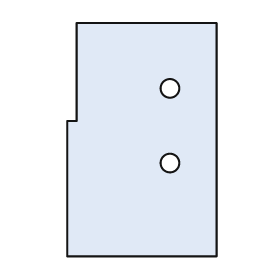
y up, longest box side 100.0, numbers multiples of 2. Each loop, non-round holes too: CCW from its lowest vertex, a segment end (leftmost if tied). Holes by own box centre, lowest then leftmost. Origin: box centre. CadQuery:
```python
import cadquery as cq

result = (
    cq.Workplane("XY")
    .moveTo(-32.0, -50.0)
    .lineTo(32.0, -50.0)
    .lineTo(32.0, 50.0)
    .lineTo(-28.0, 50.0)
    .lineTo(-28.0, 8.0)
    .lineTo(-32.0, 8.0)
    .close()
    .moveTo(12.0, -10.0)
    .circle(4.0)
    .moveTo(12.0, 22.0)
    .circle(4.0)
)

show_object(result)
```